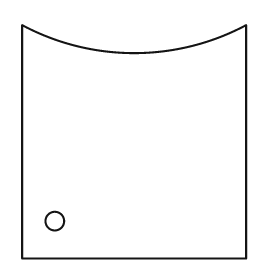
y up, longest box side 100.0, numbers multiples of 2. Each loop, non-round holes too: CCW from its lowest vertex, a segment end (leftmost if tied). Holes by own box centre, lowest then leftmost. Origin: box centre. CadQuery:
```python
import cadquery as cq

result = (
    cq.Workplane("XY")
    .moveTo(-48.0, -50.0)
    .lineTo(48.0, -50.0)
    .lineTo(48.0, 50.0)
    .threePointArc((0.0, 38.0), (-48.0, 50.0))
    .close()
    .moveTo(-34.0, -34.0)
    .circle(4.0)
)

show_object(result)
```